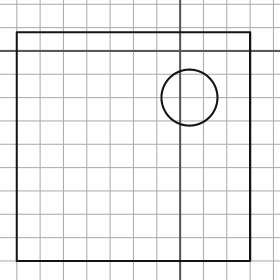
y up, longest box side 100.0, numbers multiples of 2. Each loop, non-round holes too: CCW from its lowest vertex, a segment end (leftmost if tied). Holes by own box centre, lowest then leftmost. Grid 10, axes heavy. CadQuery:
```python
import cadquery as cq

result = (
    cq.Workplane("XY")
    .moveTo(-70.0, -90.0)
    .lineTo(30.0, -90.0)
    .lineTo(30.0, 8.0)
    .lineTo(-70.0, 8.0)
    .close()
    .moveTo(4.0, -20.0)
    .circle(12.0)
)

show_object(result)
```